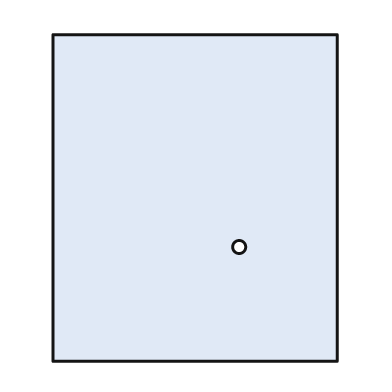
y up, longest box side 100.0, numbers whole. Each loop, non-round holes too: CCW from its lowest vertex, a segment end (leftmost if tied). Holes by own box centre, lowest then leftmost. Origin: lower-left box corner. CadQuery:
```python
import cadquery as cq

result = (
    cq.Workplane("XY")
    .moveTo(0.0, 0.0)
    .lineTo(87.0, 0.0)
    .lineTo(87.0, 100.0)
    .lineTo(0.0, 100.0)
    .close()
    .moveTo(57.0, 35.0)
    .circle(2.0)
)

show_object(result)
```